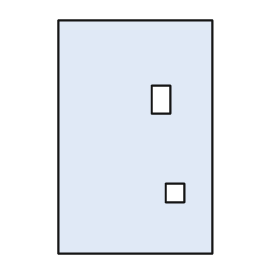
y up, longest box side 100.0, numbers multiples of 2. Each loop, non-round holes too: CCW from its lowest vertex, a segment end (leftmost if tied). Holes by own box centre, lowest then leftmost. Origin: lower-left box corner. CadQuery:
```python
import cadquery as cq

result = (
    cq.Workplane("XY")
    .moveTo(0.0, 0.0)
    .lineTo(66.0, 0.0)
    .lineTo(66.0, 100.0)
    .lineTo(0.0, 100.0)
    .close()
    .moveTo(46.0, 22.0)
    .lineTo(54.0, 22.0)
    .lineTo(54.0, 30.0)
    .lineTo(46.0, 30.0)
    .close()
    .moveTo(40.0, 60.0)
    .lineTo(48.0, 60.0)
    .lineTo(48.0, 72.0)
    .lineTo(40.0, 72.0)
    .close()
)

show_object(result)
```